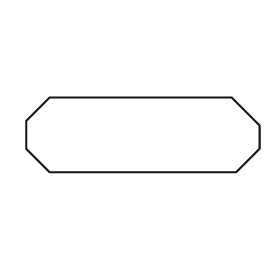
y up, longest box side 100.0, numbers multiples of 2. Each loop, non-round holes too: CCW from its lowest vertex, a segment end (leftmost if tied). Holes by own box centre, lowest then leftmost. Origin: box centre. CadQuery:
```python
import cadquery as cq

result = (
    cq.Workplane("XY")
    .moveTo(-40.0, -16.0)
    .lineTo(40.0, -16.0)
    .lineTo(50.0, -6.0)
    .lineTo(50.0, 4.0)
    .lineTo(38.0, 16.0)
    .lineTo(-40.0, 16.0)
    .lineTo(-50.0, 6.0)
    .lineTo(-50.0, -6.0)
    .close()
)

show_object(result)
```